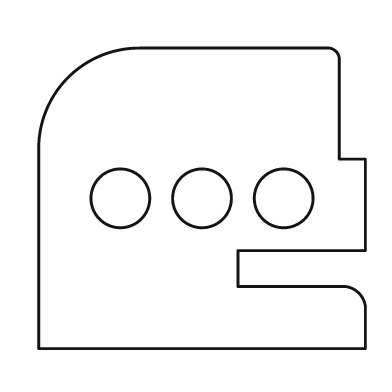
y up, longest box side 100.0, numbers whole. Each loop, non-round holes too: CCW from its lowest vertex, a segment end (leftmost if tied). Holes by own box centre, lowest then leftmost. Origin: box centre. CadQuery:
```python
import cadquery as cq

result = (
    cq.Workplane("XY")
    .moveTo(-50.0, -46.0)
    .lineTo(50.0, -46.0)
    .lineTo(50.0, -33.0)
    .threePointArc((48.0, -29.0), (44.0, -27.0))
    .lineTo(11.0, -27.0)
    .lineTo(11.0, -16.0)
    .lineTo(50.0, -16.0)
    .lineTo(50.0, 12.0)
    .lineTo(42.0, 12.0)
    .lineTo(42.0, 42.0)
    .threePointArc((41.0, 45.0), (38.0, 46.0))
    .lineTo(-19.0, 46.0)
    .threePointArc((-41.0, 37.0), (-50.0, 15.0))
    .close()
    .moveTo(-25.0, 0.0)
    .circle(9.0)
    .moveTo(0.0, 0.0)
    .circle(9.0)
    .moveTo(25.0, 0.0)
    .circle(9.0)
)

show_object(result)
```